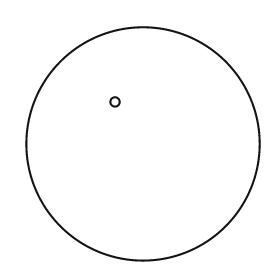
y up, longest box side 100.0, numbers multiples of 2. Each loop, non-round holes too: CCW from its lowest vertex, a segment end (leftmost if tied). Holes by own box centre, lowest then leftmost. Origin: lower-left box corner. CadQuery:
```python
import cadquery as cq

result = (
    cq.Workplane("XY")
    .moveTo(50.0, 50.0)
    .circle(50.0)
    .moveTo(38.0, 68.0)
    .circle(2.0)
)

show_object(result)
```